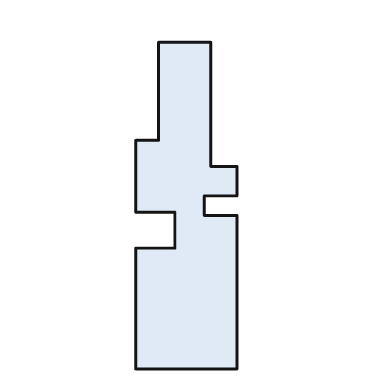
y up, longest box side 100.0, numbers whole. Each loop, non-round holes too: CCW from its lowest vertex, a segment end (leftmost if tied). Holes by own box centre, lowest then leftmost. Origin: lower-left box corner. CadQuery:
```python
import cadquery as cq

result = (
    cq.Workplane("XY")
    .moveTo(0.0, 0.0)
    .lineTo(31.0, 0.0)
    .lineTo(31.0, 47.0)
    .lineTo(21.0, 47.0)
    .lineTo(21.0, 53.0)
    .lineTo(31.0, 53.0)
    .lineTo(31.0, 62.0)
    .lineTo(23.0, 62.0)
    .lineTo(23.0, 100.0)
    .lineTo(7.0, 100.0)
    .lineTo(7.0, 70.0)
    .lineTo(0.0, 70.0)
    .lineTo(0.0, 48.0)
    .lineTo(12.0, 48.0)
    .lineTo(12.0, 37.0)
    .lineTo(0.0, 37.0)
    .close()
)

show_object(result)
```